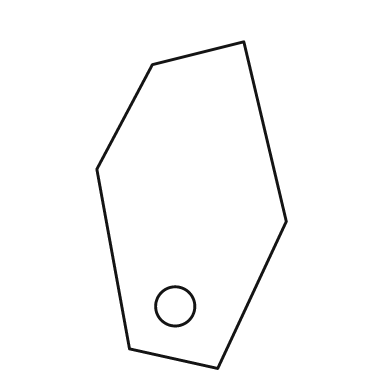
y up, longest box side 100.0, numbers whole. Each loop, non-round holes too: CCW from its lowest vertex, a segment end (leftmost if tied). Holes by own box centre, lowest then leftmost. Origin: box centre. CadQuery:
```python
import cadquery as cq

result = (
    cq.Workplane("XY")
    .moveTo(8.0, -50.0)
    .lineTo(29.0, -5.0)
    .lineTo(16.0, 50.0)
    .lineTo(-12.0, 43.0)
    .lineTo(-29.0, 11.0)
    .lineTo(-19.0, -44.0)
    .close()
    .moveTo(-5.0, -31.0)
    .circle(6.0)
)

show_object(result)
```